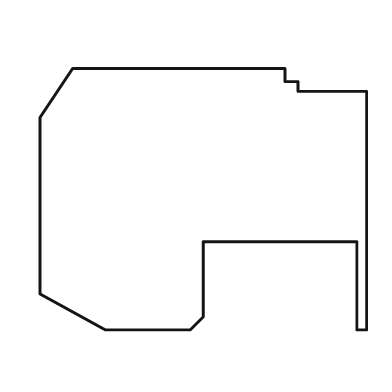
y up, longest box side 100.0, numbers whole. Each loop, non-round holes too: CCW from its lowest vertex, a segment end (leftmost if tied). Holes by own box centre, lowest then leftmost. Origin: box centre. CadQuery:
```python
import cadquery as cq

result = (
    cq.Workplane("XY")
    .moveTo(-30.0, -40.0)
    .lineTo(-4.0, -40.0)
    .lineTo(0.0, -36.0)
    .lineTo(0.0, -13.0)
    .lineTo(47.0, -13.0)
    .lineTo(47.0, -40.0)
    .lineTo(50.0, -40.0)
    .lineTo(50.0, 33.0)
    .lineTo(29.0, 33.0)
    .lineTo(29.0, 36.0)
    .lineTo(25.0, 36.0)
    .lineTo(25.0, 40.0)
    .lineTo(-40.0, 40.0)
    .lineTo(-50.0, 25.0)
    .lineTo(-50.0, -29.0)
    .close()
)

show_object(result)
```